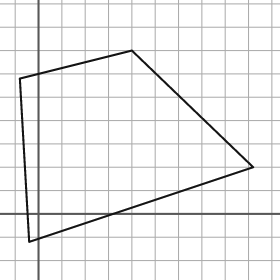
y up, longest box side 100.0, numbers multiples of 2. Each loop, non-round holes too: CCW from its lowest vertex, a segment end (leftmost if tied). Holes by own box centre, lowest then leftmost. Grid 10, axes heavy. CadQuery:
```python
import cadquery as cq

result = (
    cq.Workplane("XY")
    .moveTo(-4.0, -12.0)
    .lineTo(92.0, 20.0)
    .lineTo(40.0, 70.0)
    .lineTo(-8.0, 58.0)
    .close()
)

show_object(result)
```